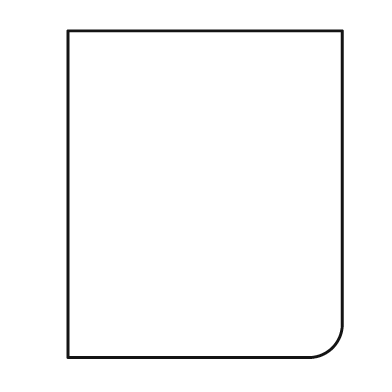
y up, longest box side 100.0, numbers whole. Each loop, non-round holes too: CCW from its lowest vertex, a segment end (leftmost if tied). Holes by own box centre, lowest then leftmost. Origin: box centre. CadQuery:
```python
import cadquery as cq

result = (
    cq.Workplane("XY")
    .moveTo(-42.0, -50.0)
    .lineTo(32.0, -50.0)
    .threePointArc((39.0, -47.0), (42.0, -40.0))
    .lineTo(42.0, 50.0)
    .lineTo(-42.0, 50.0)
    .close()
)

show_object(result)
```